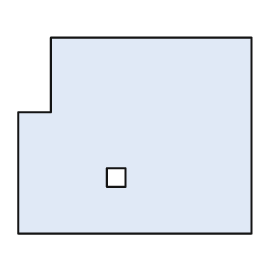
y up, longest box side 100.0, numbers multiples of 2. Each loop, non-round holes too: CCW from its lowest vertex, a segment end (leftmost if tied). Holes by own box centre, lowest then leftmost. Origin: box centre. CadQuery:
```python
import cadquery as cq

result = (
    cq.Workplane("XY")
    .moveTo(-50.0, -42.0)
    .lineTo(50.0, -42.0)
    .lineTo(50.0, 42.0)
    .lineTo(-36.0, 42.0)
    .lineTo(-36.0, 10.0)
    .lineTo(-50.0, 10.0)
    .close()
    .moveTo(-12.0, -22.0)
    .lineTo(-4.0, -22.0)
    .lineTo(-4.0, -14.0)
    .lineTo(-12.0, -14.0)
    .close()
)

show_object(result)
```